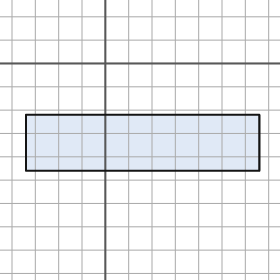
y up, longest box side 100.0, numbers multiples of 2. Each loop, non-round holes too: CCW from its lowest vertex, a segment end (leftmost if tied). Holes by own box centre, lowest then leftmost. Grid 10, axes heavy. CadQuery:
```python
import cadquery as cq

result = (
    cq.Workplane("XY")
    .moveTo(-34.0, -46.0)
    .lineTo(66.0, -46.0)
    .lineTo(66.0, -22.0)
    .lineTo(-34.0, -22.0)
    .close()
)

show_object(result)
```